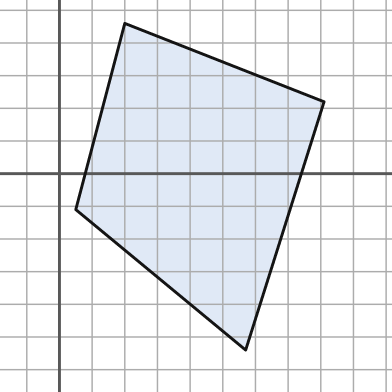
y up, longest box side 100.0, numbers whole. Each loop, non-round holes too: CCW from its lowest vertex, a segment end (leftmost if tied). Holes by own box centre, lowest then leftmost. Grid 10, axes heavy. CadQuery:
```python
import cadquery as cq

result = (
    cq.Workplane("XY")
    .moveTo(57.0, -54.0)
    .lineTo(81.0, 22.0)
    .lineTo(20.0, 46.0)
    .lineTo(5.0, -11.0)
    .close()
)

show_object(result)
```